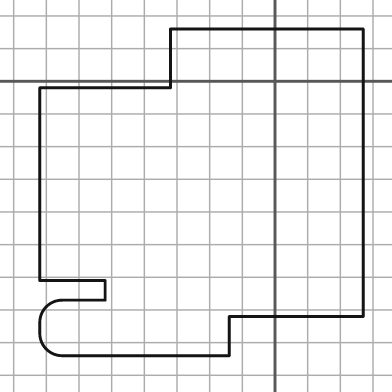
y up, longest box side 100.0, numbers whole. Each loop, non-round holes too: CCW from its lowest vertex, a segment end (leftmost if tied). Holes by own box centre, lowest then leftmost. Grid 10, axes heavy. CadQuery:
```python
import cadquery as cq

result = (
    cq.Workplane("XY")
    .moveTo(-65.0, -84.0)
    .lineTo(-14.0, -84.0)
    .lineTo(-14.0, -72.0)
    .lineTo(27.0, -72.0)
    .lineTo(27.0, 16.0)
    .lineTo(-32.0, 16.0)
    .lineTo(-32.0, -2.0)
    .lineTo(-72.0, -2.0)
    .lineTo(-72.0, -61.0)
    .lineTo(-52.0, -61.0)
    .lineTo(-52.0, -67.0)
    .lineTo(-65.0, -67.0)
    .threePointArc((-70.0, -69.0), (-72.0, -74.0))
    .lineTo(-72.0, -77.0)
    .threePointArc((-70.0, -82.0), (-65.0, -84.0))
    .close()
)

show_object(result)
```